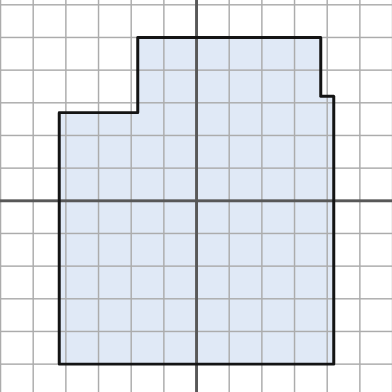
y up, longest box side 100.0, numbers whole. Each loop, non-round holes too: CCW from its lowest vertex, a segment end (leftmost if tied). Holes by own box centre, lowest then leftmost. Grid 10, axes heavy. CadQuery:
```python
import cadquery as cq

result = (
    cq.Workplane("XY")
    .moveTo(-42.0, -50.0)
    .lineTo(42.0, -50.0)
    .lineTo(42.0, 32.0)
    .lineTo(38.0, 32.0)
    .lineTo(38.0, 50.0)
    .lineTo(-18.0, 50.0)
    .lineTo(-18.0, 27.0)
    .lineTo(-42.0, 27.0)
    .close()
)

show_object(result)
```